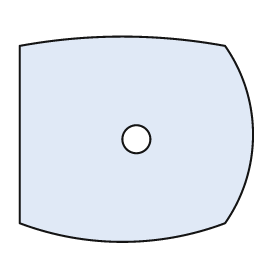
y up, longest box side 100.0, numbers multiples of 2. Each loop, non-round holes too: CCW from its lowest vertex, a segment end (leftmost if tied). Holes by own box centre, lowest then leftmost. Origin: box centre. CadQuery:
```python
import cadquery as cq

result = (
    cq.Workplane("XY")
    .moveTo(-50.0, -36.0)
    .threePointArc((-6.0, -44.0), (38.0, -36.0))
    .threePointArc((50.0, 2.0), (38.0, 40.0))
    .threePointArc((-6.0, 44.0), (-50.0, 40.0))
    .close()
    .moveTo(0.0, 0.0)
    .circle(6.0)
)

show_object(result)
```